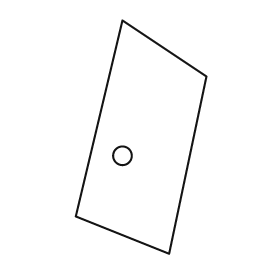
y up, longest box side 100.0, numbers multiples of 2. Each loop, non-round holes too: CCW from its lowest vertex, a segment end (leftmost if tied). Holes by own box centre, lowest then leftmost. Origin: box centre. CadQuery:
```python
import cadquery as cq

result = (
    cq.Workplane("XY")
    .moveTo(12.0, -50.0)
    .lineTo(28.0, 26.0)
    .lineTo(-8.0, 50.0)
    .lineTo(-28.0, -34.0)
    .close()
    .moveTo(-8.0, -8.0)
    .circle(4.0)
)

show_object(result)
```